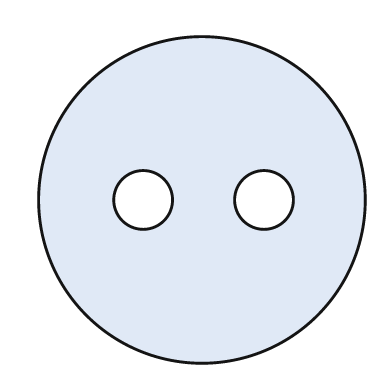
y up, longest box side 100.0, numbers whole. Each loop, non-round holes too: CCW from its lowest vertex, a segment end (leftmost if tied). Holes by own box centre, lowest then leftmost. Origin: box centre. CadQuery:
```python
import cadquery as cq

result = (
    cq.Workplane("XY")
    .moveTo(0.0, 0.0)
    .circle(50.0)
    .moveTo(-18.0, 0.0)
    .circle(9.0)
    .moveTo(19.0, 0.0)
    .circle(9.0)
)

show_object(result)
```